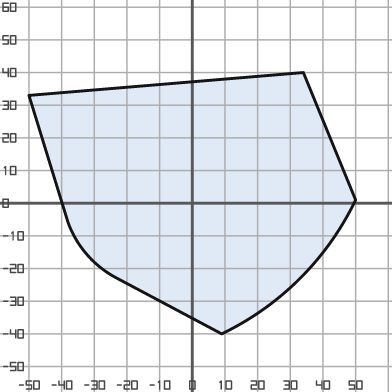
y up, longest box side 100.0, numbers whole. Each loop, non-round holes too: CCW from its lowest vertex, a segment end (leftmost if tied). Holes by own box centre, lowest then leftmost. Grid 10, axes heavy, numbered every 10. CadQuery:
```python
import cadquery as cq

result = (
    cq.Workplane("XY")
    .moveTo(9.0, -40.0)
    .threePointArc((33.0, -23.0), (50.0, 1.0))
    .lineTo(34.0, 40.0)
    .lineTo(-50.0, 33.0)
    .lineTo(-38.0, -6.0)
    .threePointArc((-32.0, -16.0), (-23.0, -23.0))
    .close()
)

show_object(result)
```